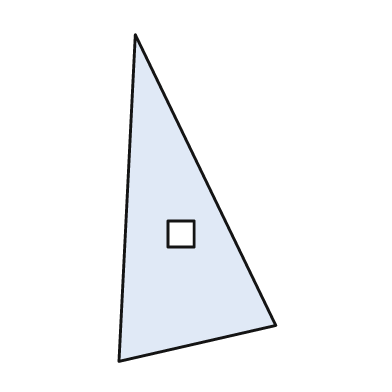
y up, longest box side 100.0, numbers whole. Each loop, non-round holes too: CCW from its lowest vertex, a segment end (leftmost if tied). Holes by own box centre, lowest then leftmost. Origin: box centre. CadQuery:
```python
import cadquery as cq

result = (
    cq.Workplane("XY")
    .moveTo(-24.0, -50.0)
    .lineTo(24.0, -39.0)
    .lineTo(-19.0, 50.0)
    .close()
    .moveTo(-9.0, -15.0)
    .lineTo(-1.0, -15.0)
    .lineTo(-1.0, -7.0)
    .lineTo(-9.0, -7.0)
    .close()
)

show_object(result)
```